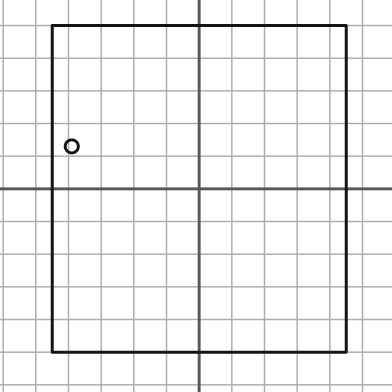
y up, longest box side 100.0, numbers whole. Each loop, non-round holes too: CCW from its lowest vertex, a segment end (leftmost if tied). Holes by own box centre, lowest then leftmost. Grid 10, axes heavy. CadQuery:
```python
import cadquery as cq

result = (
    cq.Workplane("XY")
    .moveTo(-45.0, -50.0)
    .lineTo(45.0, -50.0)
    .lineTo(45.0, 50.0)
    .lineTo(-45.0, 50.0)
    .close()
    .moveTo(-39.0, 13.0)
    .circle(2.0)
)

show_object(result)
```